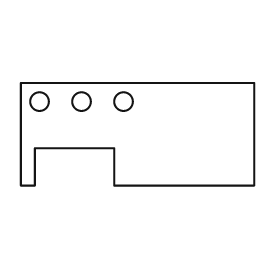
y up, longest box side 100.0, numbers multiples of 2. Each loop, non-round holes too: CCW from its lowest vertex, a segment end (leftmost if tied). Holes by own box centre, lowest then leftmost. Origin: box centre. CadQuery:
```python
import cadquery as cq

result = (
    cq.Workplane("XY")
    .moveTo(-50.0, -22.0)
    .lineTo(-44.0, -22.0)
    .lineTo(-44.0, -6.0)
    .lineTo(-10.0, -6.0)
    .lineTo(-10.0, -22.0)
    .lineTo(50.0, -22.0)
    .lineTo(50.0, 22.0)
    .lineTo(-50.0, 22.0)
    .close()
    .moveTo(-42.0, 14.0)
    .circle(4.0)
    .moveTo(-24.0, 14.0)
    .circle(4.0)
    .moveTo(-6.0, 14.0)
    .circle(4.0)
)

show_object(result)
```